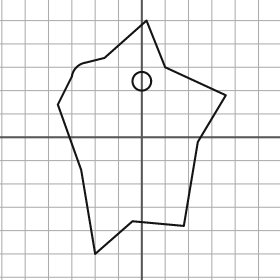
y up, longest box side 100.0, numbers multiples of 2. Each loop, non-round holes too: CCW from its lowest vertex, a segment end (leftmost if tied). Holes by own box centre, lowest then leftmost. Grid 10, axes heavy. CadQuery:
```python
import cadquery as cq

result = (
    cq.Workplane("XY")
    .moveTo(-20.0, -50.0)
    .lineTo(-4.0, -36.0)
    .lineTo(18.0, -38.0)
    .lineTo(24.0, -2.0)
    .lineTo(36.0, 18.0)
    .lineTo(10.0, 30.0)
    .lineTo(2.0, 50.0)
    .lineTo(-16.0, 34.0)
    .lineTo(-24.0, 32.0)
    .threePointArc((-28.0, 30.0), (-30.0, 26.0))
    .lineTo(-36.0, 14.0)
    .lineTo(-26.0, -14.0)
    .close()
    .moveTo(0.0, 24.0)
    .circle(4.0)
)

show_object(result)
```